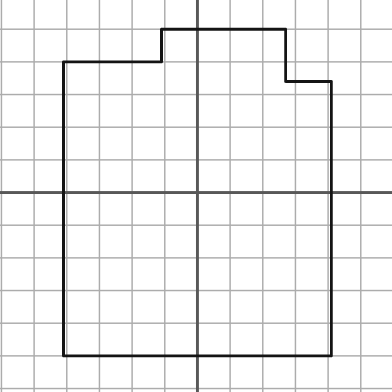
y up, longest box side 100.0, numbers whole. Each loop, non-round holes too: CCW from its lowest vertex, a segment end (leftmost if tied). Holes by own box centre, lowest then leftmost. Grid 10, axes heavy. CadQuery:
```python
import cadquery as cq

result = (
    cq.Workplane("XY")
    .moveTo(-41.0, -50.0)
    .lineTo(41.0, -50.0)
    .lineTo(41.0, 34.0)
    .lineTo(27.0, 34.0)
    .lineTo(27.0, 50.0)
    .lineTo(-11.0, 50.0)
    .lineTo(-11.0, 40.0)
    .lineTo(-41.0, 40.0)
    .close()
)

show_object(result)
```